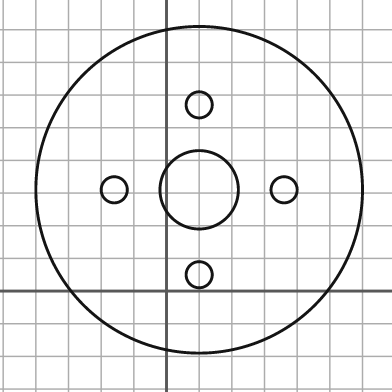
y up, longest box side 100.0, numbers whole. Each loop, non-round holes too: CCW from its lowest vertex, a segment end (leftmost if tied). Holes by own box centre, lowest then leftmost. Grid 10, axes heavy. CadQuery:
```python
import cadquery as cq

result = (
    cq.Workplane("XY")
    .moveTo(10.0, 31.0)
    .circle(50.0)
    .moveTo(10.0, 5.0)
    .circle(4.0)
    .moveTo(-16.0, 31.0)
    .circle(4.0)
    .moveTo(10.0, 31.0)
    .circle(12.0)
    .moveTo(36.0, 31.0)
    .circle(4.0)
    .moveTo(10.0, 57.0)
    .circle(4.0)
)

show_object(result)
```